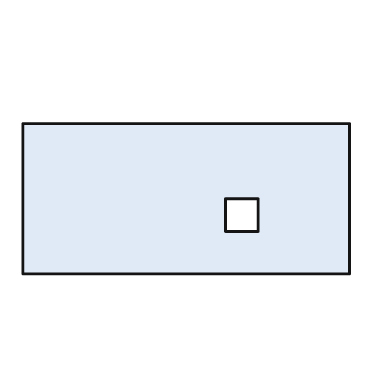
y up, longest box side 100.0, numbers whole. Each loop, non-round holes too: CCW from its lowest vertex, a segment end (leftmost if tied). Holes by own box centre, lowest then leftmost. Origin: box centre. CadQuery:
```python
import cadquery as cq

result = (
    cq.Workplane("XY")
    .moveTo(-50.0, -23.0)
    .lineTo(50.0, -23.0)
    .lineTo(50.0, 23.0)
    .lineTo(-50.0, 23.0)
    .close()
    .moveTo(12.0, -10.0)
    .lineTo(22.0, -10.0)
    .lineTo(22.0, 0.0)
    .lineTo(12.0, 0.0)
    .close()
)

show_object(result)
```